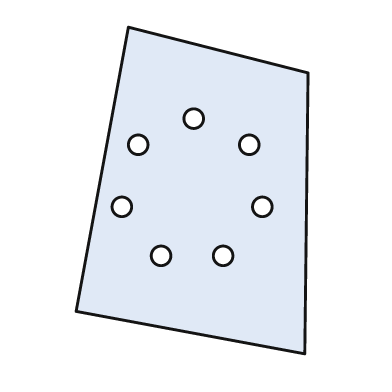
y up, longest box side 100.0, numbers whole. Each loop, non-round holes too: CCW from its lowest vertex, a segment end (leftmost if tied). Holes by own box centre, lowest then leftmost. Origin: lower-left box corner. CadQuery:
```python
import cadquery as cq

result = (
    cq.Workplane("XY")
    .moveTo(70.0, 0.0)
    .lineTo(71.0, 86.0)
    .lineTo(16.0, 100.0)
    .lineTo(0.0, 13.0)
    .close()
    .moveTo(26.0, 30.0)
    .circle(3.0)
    .moveTo(45.0, 30.0)
    .circle(3.0)
    .moveTo(14.0, 45.0)
    .circle(3.0)
    .moveTo(57.0, 45.0)
    .circle(3.0)
    .moveTo(19.0, 64.0)
    .circle(3.0)
    .moveTo(53.0, 64.0)
    .circle(3.0)
    .moveTo(36.0, 72.0)
    .circle(3.0)
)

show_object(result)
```